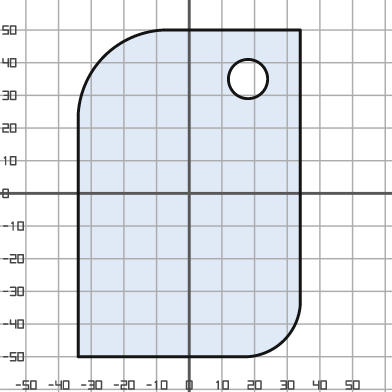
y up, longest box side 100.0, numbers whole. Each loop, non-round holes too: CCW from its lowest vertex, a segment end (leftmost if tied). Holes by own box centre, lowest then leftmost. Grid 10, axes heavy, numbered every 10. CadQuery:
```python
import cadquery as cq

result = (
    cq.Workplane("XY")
    .moveTo(-34.0, -50.0)
    .lineTo(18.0, -50.0)
    .threePointArc((29.0, -45.0), (34.0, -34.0))
    .lineTo(34.0, 50.0)
    .lineTo(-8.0, 50.0)
    .threePointArc((-26.0, 42.0), (-34.0, 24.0))
    .close()
    .moveTo(18.0, 35.0)
    .circle(6.0)
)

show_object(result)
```